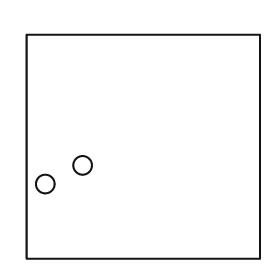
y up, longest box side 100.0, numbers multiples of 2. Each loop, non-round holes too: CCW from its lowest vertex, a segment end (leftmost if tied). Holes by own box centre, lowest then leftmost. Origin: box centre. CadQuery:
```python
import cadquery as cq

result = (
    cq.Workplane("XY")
    .moveTo(-50.0, -48.0)
    .lineTo(50.0, -48.0)
    .lineTo(50.0, 48.0)
    .lineTo(-50.0, 48.0)
    .close()
    .moveTo(-42.0, -16.0)
    .circle(4.0)
    .moveTo(-26.0, -8.0)
    .circle(4.0)
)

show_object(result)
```